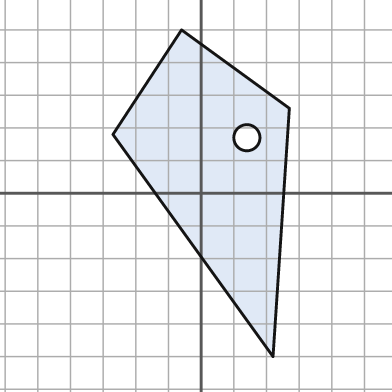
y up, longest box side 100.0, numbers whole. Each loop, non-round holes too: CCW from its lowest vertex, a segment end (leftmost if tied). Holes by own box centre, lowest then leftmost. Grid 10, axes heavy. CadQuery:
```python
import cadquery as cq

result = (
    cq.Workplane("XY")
    .moveTo(22.0, -50.0)
    .lineTo(27.0, 26.0)
    .lineTo(-6.0, 50.0)
    .lineTo(-27.0, 18.0)
    .close()
    .moveTo(14.0, 17.0)
    .circle(4.0)
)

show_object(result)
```